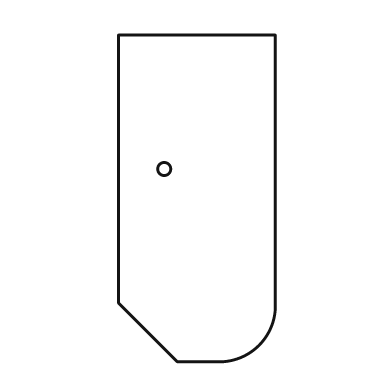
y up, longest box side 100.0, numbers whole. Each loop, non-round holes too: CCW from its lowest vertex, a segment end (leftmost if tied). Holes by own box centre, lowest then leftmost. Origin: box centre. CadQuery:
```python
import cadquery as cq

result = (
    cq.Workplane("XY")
    .moveTo(-6.0, -50.0)
    .lineTo(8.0, -50.0)
    .threePointArc((19.0, -45.0), (24.0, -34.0))
    .lineTo(24.0, 50.0)
    .lineTo(-24.0, 50.0)
    .lineTo(-24.0, -32.0)
    .close()
    .moveTo(-10.0, 9.0)
    .circle(2.0)
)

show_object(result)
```